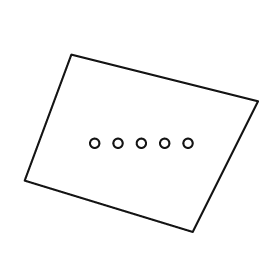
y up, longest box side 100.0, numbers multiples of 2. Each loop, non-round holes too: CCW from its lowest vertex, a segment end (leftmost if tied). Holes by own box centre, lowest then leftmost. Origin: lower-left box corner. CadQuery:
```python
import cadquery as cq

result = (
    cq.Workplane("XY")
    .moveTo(72.0, 0.0)
    .lineTo(100.0, 56.0)
    .lineTo(20.0, 76.0)
    .lineTo(0.0, 22.0)
    .close()
    .moveTo(30.0, 38.0)
    .circle(2.0)
    .moveTo(40.0, 38.0)
    .circle(2.0)
    .moveTo(50.0, 38.0)
    .circle(2.0)
    .moveTo(60.0, 38.0)
    .circle(2.0)
    .moveTo(70.0, 38.0)
    .circle(2.0)
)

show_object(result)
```